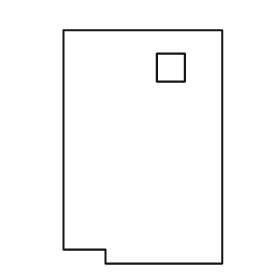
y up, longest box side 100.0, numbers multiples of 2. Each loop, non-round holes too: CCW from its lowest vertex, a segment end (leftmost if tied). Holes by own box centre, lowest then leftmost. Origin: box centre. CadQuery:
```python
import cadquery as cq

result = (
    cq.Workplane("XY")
    .moveTo(-16.0, -50.0)
    .lineTo(34.0, -50.0)
    .lineTo(34.0, 50.0)
    .lineTo(-34.0, 50.0)
    .lineTo(-34.0, -44.0)
    .lineTo(-16.0, -44.0)
    .close()
    .moveTo(6.0, 28.0)
    .lineTo(18.0, 28.0)
    .lineTo(18.0, 40.0)
    .lineTo(6.0, 40.0)
    .close()
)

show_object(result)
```